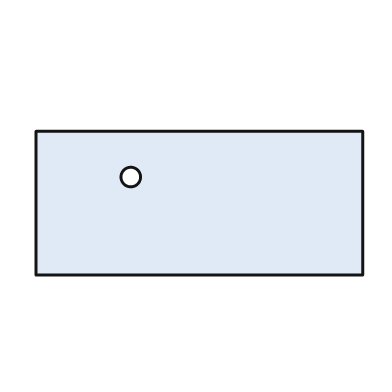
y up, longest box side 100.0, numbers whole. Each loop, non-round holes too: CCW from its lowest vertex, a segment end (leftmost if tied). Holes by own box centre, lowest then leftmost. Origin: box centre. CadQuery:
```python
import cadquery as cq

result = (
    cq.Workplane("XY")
    .moveTo(-50.0, -22.0)
    .lineTo(50.0, -22.0)
    .lineTo(50.0, 22.0)
    .lineTo(-50.0, 22.0)
    .close()
    .moveTo(-21.0, 8.0)
    .circle(3.0)
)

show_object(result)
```